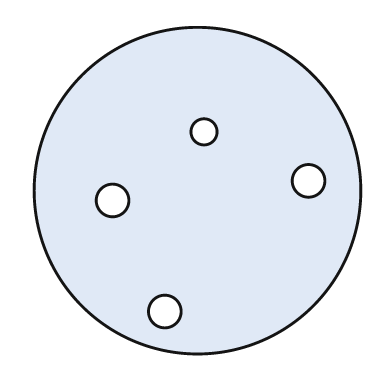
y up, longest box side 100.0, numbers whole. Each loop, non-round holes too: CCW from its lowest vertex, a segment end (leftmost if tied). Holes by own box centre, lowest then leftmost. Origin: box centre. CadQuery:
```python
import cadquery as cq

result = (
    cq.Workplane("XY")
    .moveTo(0.0, 0.0)
    .circle(50.0)
    .moveTo(-10.0, -37.0)
    .circle(5.0)
    .moveTo(-26.0, -3.0)
    .circle(5.0)
    .moveTo(34.0, 3.0)
    .circle(5.0)
    .moveTo(2.0, 18.0)
    .circle(4.0)
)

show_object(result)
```